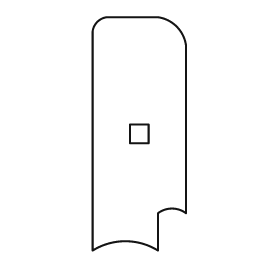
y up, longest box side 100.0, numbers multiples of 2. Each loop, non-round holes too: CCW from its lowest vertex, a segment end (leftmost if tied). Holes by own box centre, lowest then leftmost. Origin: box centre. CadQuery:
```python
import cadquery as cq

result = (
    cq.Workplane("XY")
    .moveTo(-20.0, -50.0)
    .threePointArc((-6.0, -46.0), (8.0, -50.0))
    .lineTo(8.0, -34.0)
    .threePointArc((14.0, -32.0), (20.0, -34.0))
    .lineTo(20.0, 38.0)
    .threePointArc((16.0, 46.0), (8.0, 50.0))
    .lineTo(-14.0, 50.0)
    .threePointArc((-18.0, 48.0), (-20.0, 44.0))
    .close()
    .moveTo(-4.0, -4.0)
    .lineTo(4.0, -4.0)
    .lineTo(4.0, 4.0)
    .lineTo(-4.0, 4.0)
    .close()
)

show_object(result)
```